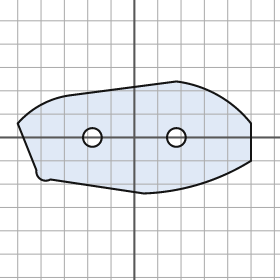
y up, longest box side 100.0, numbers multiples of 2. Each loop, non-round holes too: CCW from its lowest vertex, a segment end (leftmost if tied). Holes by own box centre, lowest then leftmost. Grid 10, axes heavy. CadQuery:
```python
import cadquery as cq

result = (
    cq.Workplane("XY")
    .moveTo(4.0, -24.0)
    .threePointArc((28.0, -20.0), (50.0, -10.0))
    .lineTo(50.0, 6.0)
    .threePointArc((36.0, 18.0), (18.0, 24.0))
    .lineTo(-28.0, 18.0)
    .threePointArc((-40.0, 14.0), (-50.0, 6.0))
    .lineTo(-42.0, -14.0)
    .threePointArc((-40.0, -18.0), (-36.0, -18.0))
    .close()
    .moveTo(-18.0, 0.0)
    .circle(4.0)
    .moveTo(18.0, 0.0)
    .circle(4.0)
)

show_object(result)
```